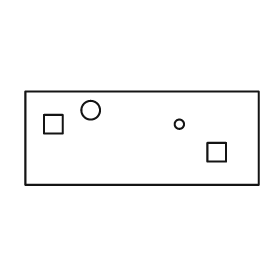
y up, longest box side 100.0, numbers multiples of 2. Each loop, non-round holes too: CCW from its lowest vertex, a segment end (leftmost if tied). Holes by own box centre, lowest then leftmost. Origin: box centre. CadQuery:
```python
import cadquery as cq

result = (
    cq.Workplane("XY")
    .moveTo(-50.0, -20.0)
    .lineTo(50.0, -20.0)
    .lineTo(50.0, 20.0)
    .lineTo(-50.0, 20.0)
    .close()
    .moveTo(28.0, -10.0)
    .lineTo(36.0, -10.0)
    .lineTo(36.0, -2.0)
    .lineTo(28.0, -2.0)
    .close()
    .moveTo(-42.0, 2.0)
    .lineTo(-34.0, 2.0)
    .lineTo(-34.0, 10.0)
    .lineTo(-42.0, 10.0)
    .close()
    .moveTo(16.0, 6.0)
    .circle(2.0)
    .moveTo(-22.0, 12.0)
    .circle(4.0)
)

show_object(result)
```